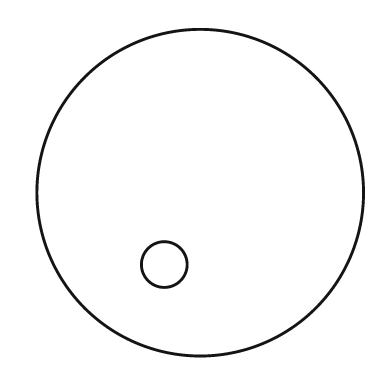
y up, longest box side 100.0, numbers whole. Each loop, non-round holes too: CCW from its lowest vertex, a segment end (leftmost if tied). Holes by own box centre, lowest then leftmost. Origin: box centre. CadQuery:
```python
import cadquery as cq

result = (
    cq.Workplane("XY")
    .moveTo(0.0, 0.0)
    .circle(50.0)
    .moveTo(-11.0, -22.0)
    .circle(7.0)
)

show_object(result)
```